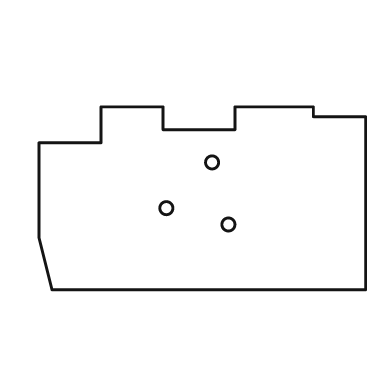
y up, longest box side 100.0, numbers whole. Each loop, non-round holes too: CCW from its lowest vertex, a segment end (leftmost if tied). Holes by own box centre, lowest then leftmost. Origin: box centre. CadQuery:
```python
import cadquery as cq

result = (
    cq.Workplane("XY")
    .moveTo(-46.0, -28.0)
    .lineTo(50.0, -28.0)
    .lineTo(50.0, 25.0)
    .lineTo(34.0, 25.0)
    .lineTo(34.0, 28.0)
    .lineTo(10.0, 28.0)
    .lineTo(10.0, 21.0)
    .lineTo(-12.0, 21.0)
    .lineTo(-12.0, 28.0)
    .lineTo(-31.0, 28.0)
    .lineTo(-31.0, 17.0)
    .lineTo(-50.0, 17.0)
    .lineTo(-50.0, -12.0)
    .close()
    .moveTo(8.0, -8.0)
    .circle(2.0)
    .moveTo(-11.0, -3.0)
    .circle(2.0)
    .moveTo(3.0, 11.0)
    .circle(2.0)
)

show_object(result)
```